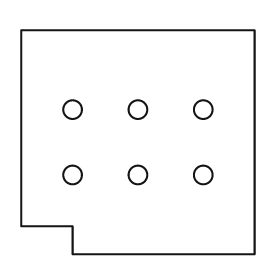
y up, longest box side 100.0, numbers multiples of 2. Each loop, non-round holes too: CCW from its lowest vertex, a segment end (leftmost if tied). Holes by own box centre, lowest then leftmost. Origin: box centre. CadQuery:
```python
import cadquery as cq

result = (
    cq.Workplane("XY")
    .moveTo(-28.0, -48.0)
    .lineTo(50.0, -48.0)
    .lineTo(50.0, 48.0)
    .lineTo(-50.0, 48.0)
    .lineTo(-50.0, -36.0)
    .lineTo(-28.0, -36.0)
    .close()
    .moveTo(-28.0, -14.0)
    .circle(4.0)
    .moveTo(0.0, -14.0)
    .circle(4.0)
    .moveTo(28.0, -14.0)
    .circle(4.0)
    .moveTo(-28.0, 14.0)
    .circle(4.0)
    .moveTo(0.0, 14.0)
    .circle(4.0)
    .moveTo(28.0, 14.0)
    .circle(4.0)
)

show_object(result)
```